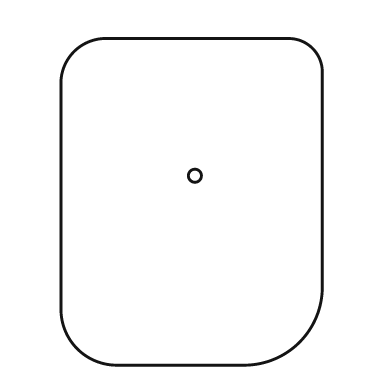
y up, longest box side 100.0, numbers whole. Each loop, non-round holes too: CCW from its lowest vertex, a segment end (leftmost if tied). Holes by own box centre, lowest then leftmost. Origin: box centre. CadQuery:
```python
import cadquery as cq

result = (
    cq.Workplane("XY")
    .moveTo(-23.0, -50.0)
    .lineTo(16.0, -50.0)
    .threePointArc((33.0, -43.0), (40.0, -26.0))
    .lineTo(40.0, 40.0)
    .threePointArc((37.0, 47.0), (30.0, 50.0))
    .lineTo(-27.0, 50.0)
    .threePointArc((-36.0, 46.0), (-40.0, 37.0))
    .lineTo(-40.0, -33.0)
    .threePointArc((-35.0, -45.0), (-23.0, -50.0))
    .close()
    .moveTo(1.0, 8.0)
    .circle(2.0)
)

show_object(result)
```